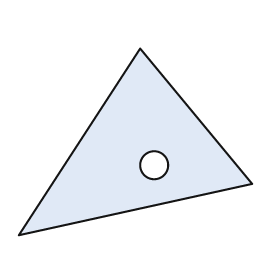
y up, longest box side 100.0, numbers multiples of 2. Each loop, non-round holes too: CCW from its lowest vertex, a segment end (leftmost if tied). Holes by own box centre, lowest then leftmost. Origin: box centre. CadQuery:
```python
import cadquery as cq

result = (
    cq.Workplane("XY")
    .moveTo(-50.0, -40.0)
    .lineTo(50.0, -18.0)
    .lineTo(2.0, 40.0)
    .close()
    .moveTo(8.0, -10.0)
    .circle(6.0)
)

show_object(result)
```